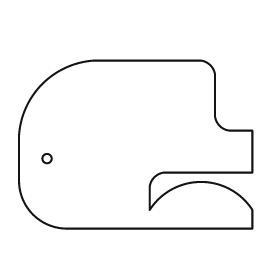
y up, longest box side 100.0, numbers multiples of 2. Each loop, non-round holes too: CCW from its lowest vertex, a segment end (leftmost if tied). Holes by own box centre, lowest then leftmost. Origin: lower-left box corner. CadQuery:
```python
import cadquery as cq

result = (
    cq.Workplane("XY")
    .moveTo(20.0, 0.0)
    .lineTo(100.0, 0.0)
    .lineTo(100.0, 8.0)
    .threePointArc((78.0, 20.0), (56.0, 8.0))
    .lineTo(56.0, 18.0)
    .threePointArc((58.0, 22.0), (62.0, 24.0))
    .lineTo(100.0, 24.0)
    .lineTo(100.0, 42.0)
    .lineTo(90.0, 42.0)
    .threePointArc((86.0, 44.0), (84.0, 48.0))
    .lineTo(84.0, 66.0)
    .threePointArc((82.0, 70.0), (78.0, 72.0))
    .lineTo(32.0, 72.0)
    .threePointArc((10.0, 62.0), (0.0, 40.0))
    .lineTo(0.0, 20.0)
    .threePointArc((6.0, 6.0), (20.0, 0.0))
    .close()
    .moveTo(12.0, 30.0)
    .circle(2.0)
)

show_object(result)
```